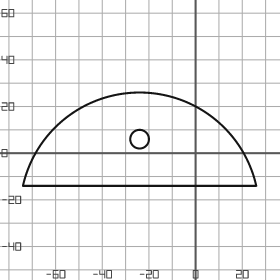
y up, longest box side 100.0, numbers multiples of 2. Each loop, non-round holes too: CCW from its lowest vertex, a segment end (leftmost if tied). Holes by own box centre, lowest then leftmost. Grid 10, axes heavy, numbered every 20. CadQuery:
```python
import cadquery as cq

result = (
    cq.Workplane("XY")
    .moveTo(-74.0, -14.0)
    .lineTo(26.0, -14.0)
    .threePointArc((-24.0, 26.0), (-74.0, -14.0))
    .close()
    .moveTo(-24.0, 6.0)
    .circle(4.0)
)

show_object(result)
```